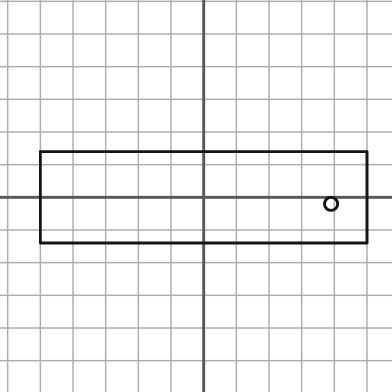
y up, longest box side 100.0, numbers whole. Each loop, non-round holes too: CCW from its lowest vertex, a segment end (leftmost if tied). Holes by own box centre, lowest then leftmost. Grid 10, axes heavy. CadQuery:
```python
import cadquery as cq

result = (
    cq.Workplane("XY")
    .moveTo(-50.0, -14.0)
    .lineTo(50.0, -14.0)
    .lineTo(50.0, 14.0)
    .lineTo(-50.0, 14.0)
    .close()
    .moveTo(39.0, -2.0)
    .circle(2.0)
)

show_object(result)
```